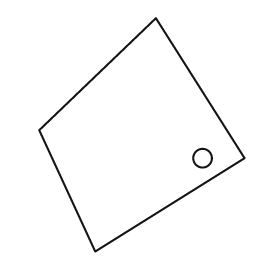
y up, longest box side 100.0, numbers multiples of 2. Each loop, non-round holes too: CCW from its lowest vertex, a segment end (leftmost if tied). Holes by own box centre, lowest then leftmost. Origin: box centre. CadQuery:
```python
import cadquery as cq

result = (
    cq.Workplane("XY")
    .moveTo(-20.0, -50.0)
    .lineTo(44.0, -10.0)
    .lineTo(6.0, 50.0)
    .lineTo(-44.0, 2.0)
    .close()
    .moveTo(26.0, -10.0)
    .circle(4.0)
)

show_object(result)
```